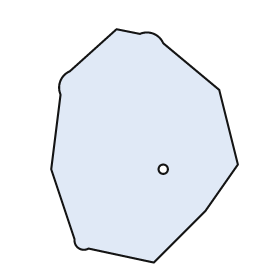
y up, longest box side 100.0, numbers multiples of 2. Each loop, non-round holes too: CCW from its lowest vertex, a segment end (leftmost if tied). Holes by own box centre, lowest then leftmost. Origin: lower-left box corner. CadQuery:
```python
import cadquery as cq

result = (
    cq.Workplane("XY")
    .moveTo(44.0, 0.0)
    .lineTo(66.0, 22.0)
    .lineTo(80.0, 42.0)
    .lineTo(72.0, 74.0)
    .lineTo(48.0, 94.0)
    .threePointArc((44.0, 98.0), (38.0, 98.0))
    .lineTo(28.0, 100.0)
    .lineTo(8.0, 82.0)
    .threePointArc((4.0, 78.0), (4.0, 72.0))
    .lineTo(0.0, 40.0)
    .lineTo(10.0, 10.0)
    .threePointArc((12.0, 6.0), (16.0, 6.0))
    .close()
    .moveTo(48.0, 40.0)
    .circle(2.0)
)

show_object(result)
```